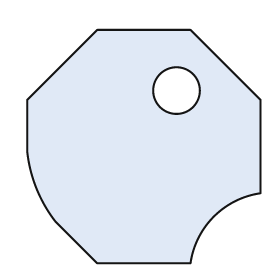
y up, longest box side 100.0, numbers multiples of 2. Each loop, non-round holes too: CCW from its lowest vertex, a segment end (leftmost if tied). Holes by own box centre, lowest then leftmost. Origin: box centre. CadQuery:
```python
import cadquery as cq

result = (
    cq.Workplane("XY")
    .moveTo(-20.0, -50.0)
    .lineTo(20.0, -50.0)
    .threePointArc((30.0, -30.0), (50.0, -20.0))
    .lineTo(50.0, 20.0)
    .lineTo(20.0, 50.0)
    .lineTo(-20.0, 50.0)
    .lineTo(-50.0, 20.0)
    .lineTo(-50.0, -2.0)
    .threePointArc((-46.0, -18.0), (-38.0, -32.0))
    .close()
    .moveTo(14.0, 24.0)
    .circle(10.0)
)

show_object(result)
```